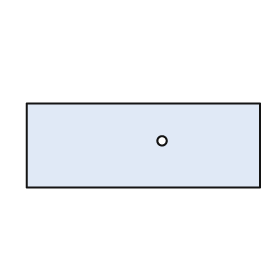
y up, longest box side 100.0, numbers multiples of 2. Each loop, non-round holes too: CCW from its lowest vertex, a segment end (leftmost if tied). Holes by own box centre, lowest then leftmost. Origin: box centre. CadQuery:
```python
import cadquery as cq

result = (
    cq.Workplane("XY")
    .moveTo(-50.0, -18.0)
    .lineTo(50.0, -18.0)
    .lineTo(50.0, 18.0)
    .lineTo(-50.0, 18.0)
    .close()
    .moveTo(8.0, 2.0)
    .circle(2.0)
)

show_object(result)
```